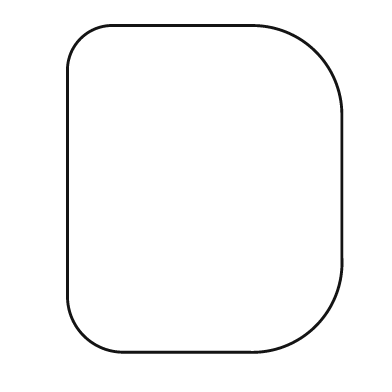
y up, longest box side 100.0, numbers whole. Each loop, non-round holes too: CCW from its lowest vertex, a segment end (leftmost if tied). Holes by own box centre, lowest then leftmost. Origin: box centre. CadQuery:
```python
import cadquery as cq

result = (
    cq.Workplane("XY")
    .moveTo(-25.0, -50.0)
    .lineTo(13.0, -50.0)
    .threePointArc((34.0, -42.0), (42.0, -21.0))
    .lineTo(42.0, 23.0)
    .threePointArc((34.0, 42.0), (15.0, 50.0))
    .lineTo(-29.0, 50.0)
    .threePointArc((-38.0, 46.0), (-42.0, 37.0))
    .lineTo(-42.0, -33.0)
    .threePointArc((-37.0, -45.0), (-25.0, -50.0))
    .close()
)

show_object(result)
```